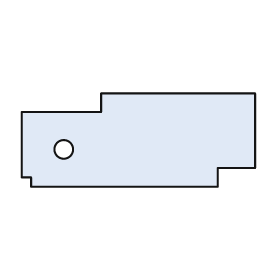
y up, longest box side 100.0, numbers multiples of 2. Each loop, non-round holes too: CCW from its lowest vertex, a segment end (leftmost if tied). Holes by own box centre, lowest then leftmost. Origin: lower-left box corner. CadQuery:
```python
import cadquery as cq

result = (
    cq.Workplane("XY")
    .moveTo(4.0, 0.0)
    .lineTo(84.0, 0.0)
    .lineTo(84.0, 8.0)
    .lineTo(100.0, 8.0)
    .lineTo(100.0, 40.0)
    .lineTo(34.0, 40.0)
    .lineTo(34.0, 32.0)
    .lineTo(0.0, 32.0)
    .lineTo(0.0, 4.0)
    .lineTo(4.0, 4.0)
    .close()
    .moveTo(18.0, 16.0)
    .circle(4.0)
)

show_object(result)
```